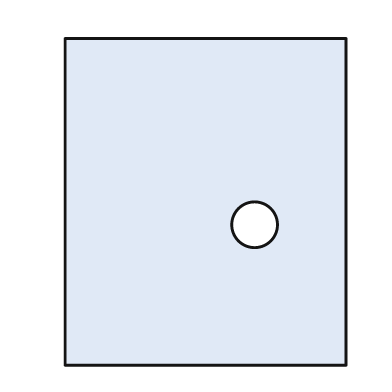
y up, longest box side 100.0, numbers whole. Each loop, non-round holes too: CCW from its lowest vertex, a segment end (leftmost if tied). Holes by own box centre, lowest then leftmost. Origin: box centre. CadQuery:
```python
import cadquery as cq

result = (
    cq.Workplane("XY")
    .moveTo(-43.0, -50.0)
    .lineTo(43.0, -50.0)
    .lineTo(43.0, 50.0)
    .lineTo(-43.0, 50.0)
    .close()
    .moveTo(15.0, -7.0)
    .circle(7.0)
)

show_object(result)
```